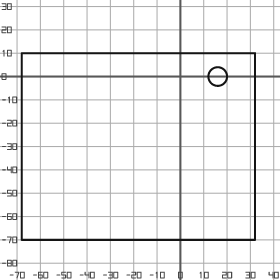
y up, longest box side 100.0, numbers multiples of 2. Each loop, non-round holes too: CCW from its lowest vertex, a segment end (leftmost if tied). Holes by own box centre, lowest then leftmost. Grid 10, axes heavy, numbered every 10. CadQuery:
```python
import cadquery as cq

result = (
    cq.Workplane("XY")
    .moveTo(-68.0, -70.0)
    .lineTo(32.0, -70.0)
    .lineTo(32.0, 10.0)
    .lineTo(-68.0, 10.0)
    .close()
    .moveTo(16.0, 0.0)
    .circle(4.0)
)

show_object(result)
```